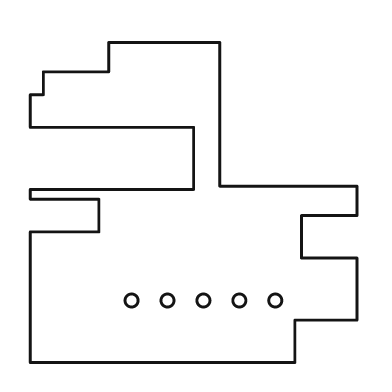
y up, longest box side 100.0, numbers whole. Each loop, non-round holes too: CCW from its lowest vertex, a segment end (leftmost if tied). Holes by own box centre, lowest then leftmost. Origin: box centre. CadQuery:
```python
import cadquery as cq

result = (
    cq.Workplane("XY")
    .moveTo(-50.0, -49.0)
    .lineTo(31.0, -49.0)
    .lineTo(31.0, -36.0)
    .lineTo(50.0, -36.0)
    .lineTo(50.0, -17.0)
    .lineTo(33.0, -17.0)
    .lineTo(33.0, -4.0)
    .lineTo(50.0, -4.0)
    .lineTo(50.0, 5.0)
    .lineTo(8.0, 5.0)
    .lineTo(8.0, 49.0)
    .lineTo(-26.0, 49.0)
    .lineTo(-26.0, 40.0)
    .lineTo(-46.0, 40.0)
    .lineTo(-46.0, 33.0)
    .lineTo(-50.0, 33.0)
    .lineTo(-50.0, 23.0)
    .lineTo(0.0, 23.0)
    .lineTo(0.0, 4.0)
    .lineTo(-50.0, 4.0)
    .lineTo(-50.0, 1.0)
    .lineTo(-29.0, 1.0)
    .lineTo(-29.0, -9.0)
    .lineTo(-50.0, -9.0)
    .close()
    .moveTo(-19.0, -30.0)
    .circle(2.0)
    .moveTo(-8.0, -30.0)
    .circle(2.0)
    .moveTo(3.0, -30.0)
    .circle(2.0)
    .moveTo(14.0, -30.0)
    .circle(2.0)
    .moveTo(25.0, -30.0)
    .circle(2.0)
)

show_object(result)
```